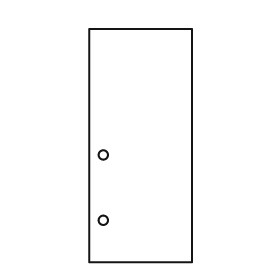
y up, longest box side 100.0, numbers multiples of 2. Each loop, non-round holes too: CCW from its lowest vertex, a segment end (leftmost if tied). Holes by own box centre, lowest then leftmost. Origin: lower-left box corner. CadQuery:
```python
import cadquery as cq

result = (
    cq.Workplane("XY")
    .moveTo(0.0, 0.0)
    .lineTo(44.0, 0.0)
    .lineTo(44.0, 100.0)
    .lineTo(0.0, 100.0)
    .close()
    .moveTo(6.0, 18.0)
    .circle(2.0)
    .moveTo(6.0, 46.0)
    .circle(2.0)
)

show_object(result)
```